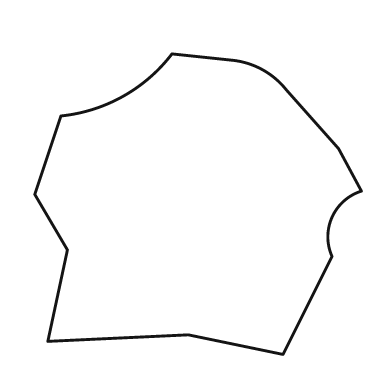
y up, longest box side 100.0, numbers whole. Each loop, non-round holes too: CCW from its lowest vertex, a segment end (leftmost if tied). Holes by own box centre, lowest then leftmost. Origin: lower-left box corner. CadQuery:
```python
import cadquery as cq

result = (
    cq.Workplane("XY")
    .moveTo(76.0, 0.0)
    .lineTo(91.0, 30.0)
    .threePointArc((91.0, 42.0), (100.0, 50.0))
    .lineTo(93.0, 63.0)
    .lineTo(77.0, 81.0)
    .threePointArc((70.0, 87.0), (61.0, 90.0))
    .lineTo(42.0, 92.0)
    .threePointArc((27.0, 79.0), (8.0, 73.0))
    .lineTo(0.0, 49.0)
    .lineTo(10.0, 32.0)
    .lineTo(4.0, 4.0)
    .lineTo(47.0, 6.0)
    .close()
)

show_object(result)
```